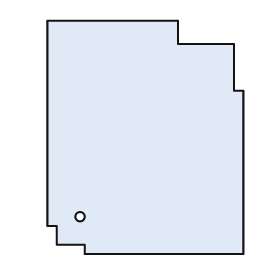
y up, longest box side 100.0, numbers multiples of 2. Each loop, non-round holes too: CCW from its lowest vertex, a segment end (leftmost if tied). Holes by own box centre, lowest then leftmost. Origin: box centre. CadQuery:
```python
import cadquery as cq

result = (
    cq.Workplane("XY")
    .moveTo(-26.0, -50.0)
    .lineTo(42.0, -50.0)
    .lineTo(42.0, 20.0)
    .lineTo(38.0, 20.0)
    .lineTo(38.0, 40.0)
    .lineTo(14.0, 40.0)
    .lineTo(14.0, 50.0)
    .lineTo(-42.0, 50.0)
    .lineTo(-42.0, -38.0)
    .lineTo(-38.0, -38.0)
    .lineTo(-38.0, -46.0)
    .lineTo(-26.0, -46.0)
    .close()
    .moveTo(-28.0, -34.0)
    .circle(2.0)
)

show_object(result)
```